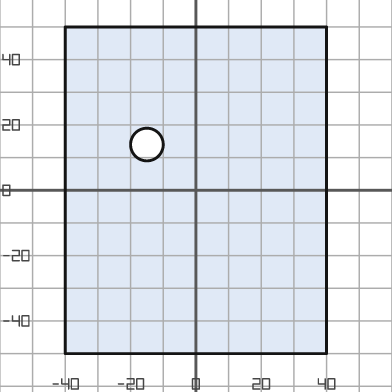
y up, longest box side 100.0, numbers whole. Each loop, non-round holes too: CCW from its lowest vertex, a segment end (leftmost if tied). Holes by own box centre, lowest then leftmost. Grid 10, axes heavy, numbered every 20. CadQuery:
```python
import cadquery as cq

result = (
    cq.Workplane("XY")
    .moveTo(-40.0, -50.0)
    .lineTo(40.0, -50.0)
    .lineTo(40.0, 50.0)
    .lineTo(-40.0, 50.0)
    .close()
    .moveTo(-15.0, 14.0)
    .circle(5.0)
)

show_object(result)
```